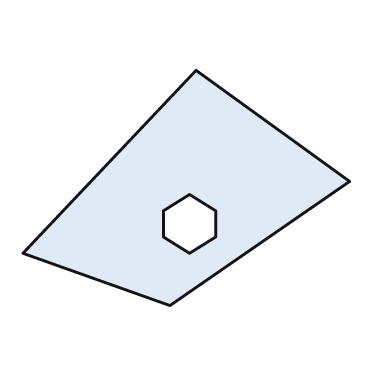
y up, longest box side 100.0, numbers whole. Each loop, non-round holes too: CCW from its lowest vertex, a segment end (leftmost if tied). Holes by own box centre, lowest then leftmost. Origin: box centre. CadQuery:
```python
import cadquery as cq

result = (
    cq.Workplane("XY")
    .moveTo(-5.0, -36.0)
    .lineTo(50.0, 2.0)
    .lineTo(3.0, 36.0)
    .lineTo(-50.0, -20.0)
    .close()
    .moveTo(1.0, -20.0)
    .lineTo(9.0, -15.0)
    .lineTo(9.0, -7.0)
    .lineTo(1.0, -2.0)
    .lineTo(-7.0, -7.0)
    .lineTo(-7.0, -15.0)
    .close()
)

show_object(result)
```